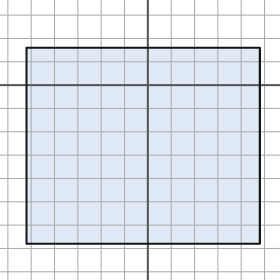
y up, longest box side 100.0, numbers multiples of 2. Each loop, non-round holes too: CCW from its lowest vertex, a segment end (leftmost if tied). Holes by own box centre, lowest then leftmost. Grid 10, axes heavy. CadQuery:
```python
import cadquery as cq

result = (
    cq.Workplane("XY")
    .moveTo(-52.0, -68.0)
    .lineTo(48.0, -68.0)
    .lineTo(48.0, 16.0)
    .lineTo(-52.0, 16.0)
    .close()
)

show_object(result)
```